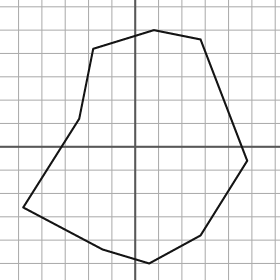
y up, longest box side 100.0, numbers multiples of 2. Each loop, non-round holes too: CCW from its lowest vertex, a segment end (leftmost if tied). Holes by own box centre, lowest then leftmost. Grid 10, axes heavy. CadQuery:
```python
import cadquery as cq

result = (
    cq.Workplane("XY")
    .moveTo(6.0, -50.0)
    .lineTo(28.0, -38.0)
    .lineTo(48.0, -6.0)
    .lineTo(28.0, 46.0)
    .lineTo(8.0, 50.0)
    .lineTo(-18.0, 42.0)
    .lineTo(-24.0, 12.0)
    .lineTo(-48.0, -26.0)
    .lineTo(-14.0, -44.0)
    .close()
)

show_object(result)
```